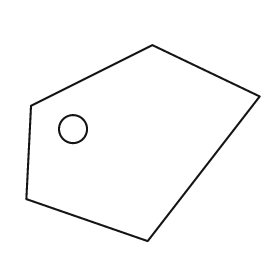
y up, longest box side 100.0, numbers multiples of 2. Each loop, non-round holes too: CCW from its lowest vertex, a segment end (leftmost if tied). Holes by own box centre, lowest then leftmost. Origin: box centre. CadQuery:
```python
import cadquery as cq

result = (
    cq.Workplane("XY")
    .moveTo(2.0, -42.0)
    .lineTo(50.0, 20.0)
    .lineTo(4.0, 42.0)
    .lineTo(-48.0, 16.0)
    .lineTo(-50.0, -24.0)
    .close()
    .moveTo(-30.0, 6.0)
    .circle(6.0)
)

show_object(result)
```